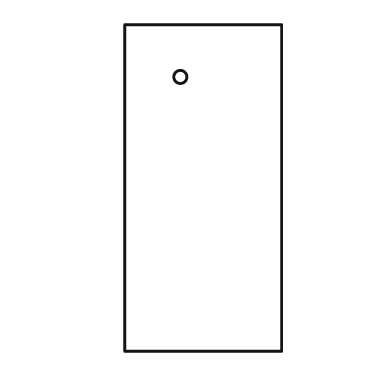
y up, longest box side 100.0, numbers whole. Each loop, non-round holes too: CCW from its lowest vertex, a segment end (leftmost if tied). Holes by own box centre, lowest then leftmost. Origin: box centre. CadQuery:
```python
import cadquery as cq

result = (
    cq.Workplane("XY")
    .moveTo(-24.0, -50.0)
    .lineTo(24.0, -50.0)
    .lineTo(24.0, 50.0)
    .lineTo(-24.0, 50.0)
    .close()
    .moveTo(-7.0, 34.0)
    .circle(2.0)
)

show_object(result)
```